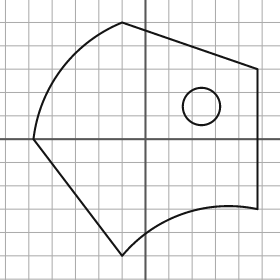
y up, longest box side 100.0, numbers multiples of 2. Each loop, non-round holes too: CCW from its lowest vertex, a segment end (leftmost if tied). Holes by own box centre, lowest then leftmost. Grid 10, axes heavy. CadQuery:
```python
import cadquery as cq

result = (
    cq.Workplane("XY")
    .moveTo(-10.0, -50.0)
    .threePointArc((16.0, -32.0), (48.0, -30.0))
    .lineTo(48.0, 30.0)
    .lineTo(-10.0, 50.0)
    .threePointArc((-36.0, 30.0), (-48.0, 0.0))
    .close()
    .moveTo(24.0, 14.0)
    .circle(8.0)
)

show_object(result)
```